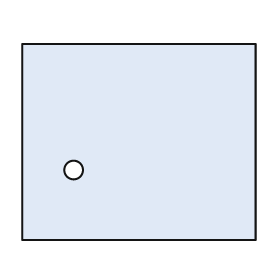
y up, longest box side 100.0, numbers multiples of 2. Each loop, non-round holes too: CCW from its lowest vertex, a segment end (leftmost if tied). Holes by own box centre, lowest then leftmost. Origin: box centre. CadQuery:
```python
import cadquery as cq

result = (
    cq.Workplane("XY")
    .moveTo(-50.0, -42.0)
    .lineTo(50.0, -42.0)
    .lineTo(50.0, 42.0)
    .lineTo(-50.0, 42.0)
    .close()
    .moveTo(-28.0, -12.0)
    .circle(4.0)
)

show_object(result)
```